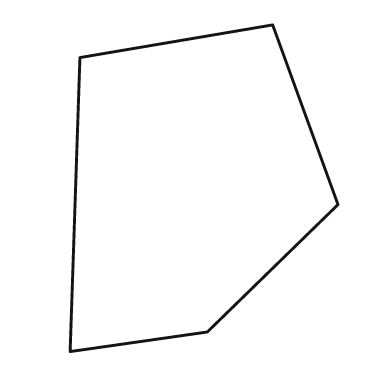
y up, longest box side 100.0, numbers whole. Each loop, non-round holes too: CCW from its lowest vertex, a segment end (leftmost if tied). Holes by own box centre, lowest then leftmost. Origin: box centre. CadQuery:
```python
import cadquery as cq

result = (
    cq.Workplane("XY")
    .moveTo(-41.0, -50.0)
    .lineTo(1.0, -44.0)
    .lineTo(41.0, -5.0)
    .lineTo(21.0, 50.0)
    .lineTo(-38.0, 40.0)
    .close()
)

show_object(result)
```